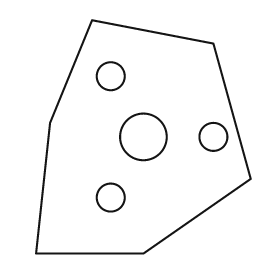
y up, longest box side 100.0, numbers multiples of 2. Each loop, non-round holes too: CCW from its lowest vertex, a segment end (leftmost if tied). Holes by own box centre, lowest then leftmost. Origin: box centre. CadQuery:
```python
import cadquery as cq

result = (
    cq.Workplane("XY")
    .moveTo(-46.0, -50.0)
    .lineTo(0.0, -50.0)
    .lineTo(46.0, -18.0)
    .lineTo(30.0, 40.0)
    .lineTo(-22.0, 50.0)
    .lineTo(-40.0, 6.0)
    .close()
    .moveTo(-14.0, -26.0)
    .circle(6.0)
    .moveTo(0.0, 0.0)
    .circle(10.0)
    .moveTo(30.0, 0.0)
    .circle(6.0)
    .moveTo(-14.0, 26.0)
    .circle(6.0)
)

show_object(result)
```